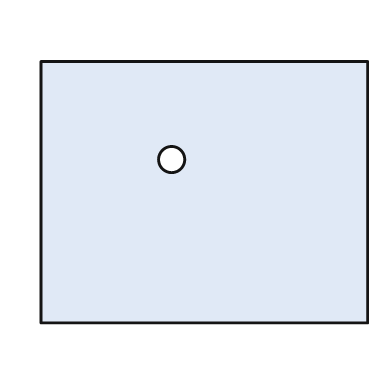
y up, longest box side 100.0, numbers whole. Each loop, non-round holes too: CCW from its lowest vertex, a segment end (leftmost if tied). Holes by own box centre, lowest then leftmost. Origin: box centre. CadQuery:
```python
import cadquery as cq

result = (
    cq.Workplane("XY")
    .moveTo(-50.0, -40.0)
    .lineTo(50.0, -40.0)
    .lineTo(50.0, 40.0)
    .lineTo(-50.0, 40.0)
    .close()
    .moveTo(-10.0, 10.0)
    .circle(4.0)
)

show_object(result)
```